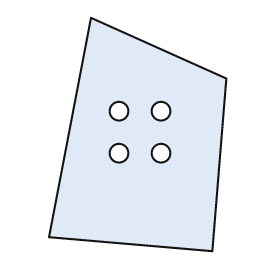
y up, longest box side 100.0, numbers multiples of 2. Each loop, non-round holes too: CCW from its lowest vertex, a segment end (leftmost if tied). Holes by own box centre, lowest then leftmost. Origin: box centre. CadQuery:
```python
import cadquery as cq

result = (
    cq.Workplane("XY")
    .moveTo(32.0, -50.0)
    .lineTo(38.0, 24.0)
    .lineTo(-20.0, 50.0)
    .lineTo(-38.0, -44.0)
    .close()
    .moveTo(-8.0, -8.0)
    .circle(4.0)
    .moveTo(10.0, -8.0)
    .circle(4.0)
    .moveTo(-8.0, 10.0)
    .circle(4.0)
    .moveTo(10.0, 10.0)
    .circle(4.0)
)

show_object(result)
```